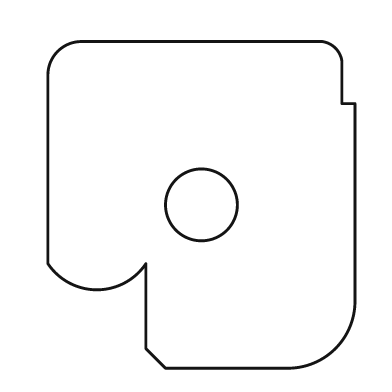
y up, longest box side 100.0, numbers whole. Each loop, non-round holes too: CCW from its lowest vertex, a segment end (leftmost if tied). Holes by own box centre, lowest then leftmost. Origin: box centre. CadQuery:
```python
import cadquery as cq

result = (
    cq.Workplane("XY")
    .moveTo(-11.0, -50.0)
    .lineTo(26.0, -50.0)
    .threePointArc((41.0, -44.0), (47.0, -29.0))
    .lineTo(47.0, 31.0)
    .lineTo(43.0, 31.0)
    .lineTo(43.0, 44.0)
    .threePointArc((41.0, 48.0), (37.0, 50.0))
    .lineTo(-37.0, 50.0)
    .threePointArc((-44.0, 47.0), (-47.0, 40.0))
    .lineTo(-47.0, -18.0)
    .threePointArc((-32.0, -26.0), (-17.0, -18.0))
    .lineTo(-17.0, -44.0)
    .close()
    .moveTo(0.0, 0.0)
    .circle(11.0)
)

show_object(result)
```